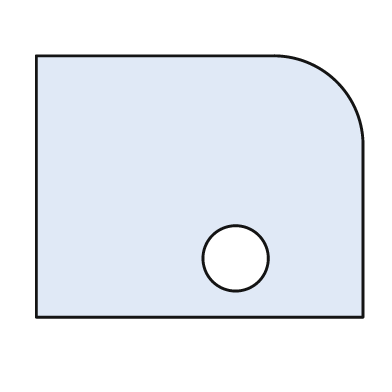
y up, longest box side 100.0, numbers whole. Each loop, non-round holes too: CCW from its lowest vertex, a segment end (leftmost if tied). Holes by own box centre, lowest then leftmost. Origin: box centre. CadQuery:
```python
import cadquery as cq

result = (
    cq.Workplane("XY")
    .moveTo(-50.0, -40.0)
    .lineTo(50.0, -40.0)
    .lineTo(50.0, 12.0)
    .threePointArc((42.0, 32.0), (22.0, 40.0))
    .lineTo(-50.0, 40.0)
    .close()
    .moveTo(11.0, -22.0)
    .circle(10.0)
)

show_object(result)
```